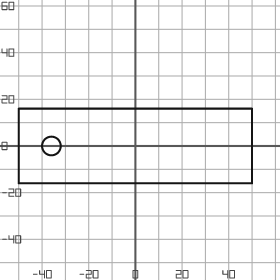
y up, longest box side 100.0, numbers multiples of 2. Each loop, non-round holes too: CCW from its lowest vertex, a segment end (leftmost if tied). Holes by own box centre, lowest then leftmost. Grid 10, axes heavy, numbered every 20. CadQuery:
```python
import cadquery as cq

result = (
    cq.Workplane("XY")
    .moveTo(-50.0, -16.0)
    .lineTo(50.0, -16.0)
    .lineTo(50.0, 16.0)
    .lineTo(-50.0, 16.0)
    .close()
    .moveTo(-36.0, 0.0)
    .circle(4.0)
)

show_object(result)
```